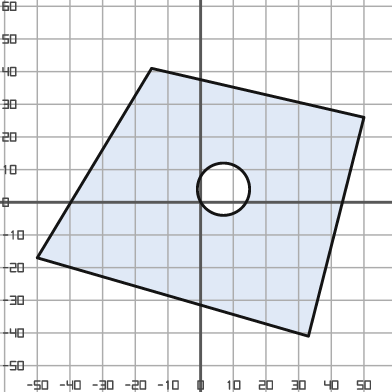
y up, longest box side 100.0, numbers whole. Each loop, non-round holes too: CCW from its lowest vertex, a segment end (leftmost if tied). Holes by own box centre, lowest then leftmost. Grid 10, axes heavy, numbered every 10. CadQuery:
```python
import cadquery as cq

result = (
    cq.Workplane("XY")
    .moveTo(33.0, -41.0)
    .lineTo(50.0, 26.0)
    .lineTo(-15.0, 41.0)
    .lineTo(-50.0, -17.0)
    .close()
    .moveTo(7.0, 4.0)
    .circle(8.0)
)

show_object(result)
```